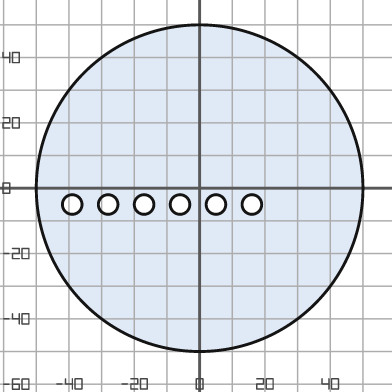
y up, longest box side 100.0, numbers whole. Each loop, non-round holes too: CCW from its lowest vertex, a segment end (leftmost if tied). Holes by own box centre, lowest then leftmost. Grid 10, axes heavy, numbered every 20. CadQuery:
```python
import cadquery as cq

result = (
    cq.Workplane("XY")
    .moveTo(0.0, 0.0)
    .circle(50.0)
    .moveTo(-39.0, -5.0)
    .circle(3.0)
    .moveTo(-28.0, -5.0)
    .circle(3.0)
    .moveTo(-17.0, -5.0)
    .circle(3.0)
    .moveTo(-6.0, -5.0)
    .circle(3.0)
    .moveTo(5.0, -5.0)
    .circle(3.0)
    .moveTo(16.0, -5.0)
    .circle(3.0)
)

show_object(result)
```